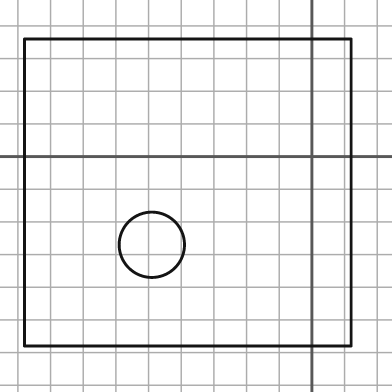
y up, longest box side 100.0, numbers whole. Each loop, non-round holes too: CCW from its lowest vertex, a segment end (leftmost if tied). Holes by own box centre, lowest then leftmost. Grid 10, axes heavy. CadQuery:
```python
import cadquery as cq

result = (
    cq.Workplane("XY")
    .moveTo(-88.0, -58.0)
    .lineTo(12.0, -58.0)
    .lineTo(12.0, 36.0)
    .lineTo(-88.0, 36.0)
    .close()
    .moveTo(-49.0, -27.0)
    .circle(10.0)
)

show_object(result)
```